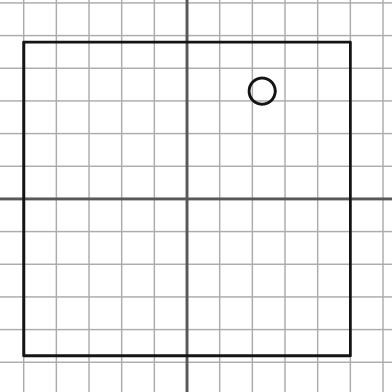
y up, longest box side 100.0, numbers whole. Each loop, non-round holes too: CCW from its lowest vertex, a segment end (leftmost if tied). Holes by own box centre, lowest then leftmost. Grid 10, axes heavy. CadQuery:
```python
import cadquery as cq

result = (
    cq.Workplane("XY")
    .moveTo(-50.0, -48.0)
    .lineTo(50.0, -48.0)
    .lineTo(50.0, 48.0)
    .lineTo(-50.0, 48.0)
    .close()
    .moveTo(23.0, 33.0)
    .circle(4.0)
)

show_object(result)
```